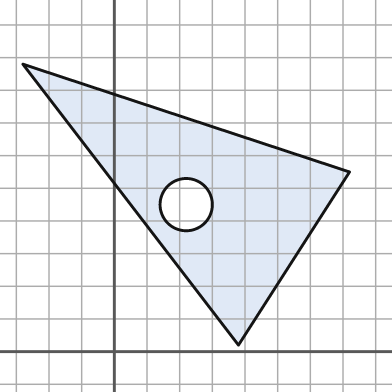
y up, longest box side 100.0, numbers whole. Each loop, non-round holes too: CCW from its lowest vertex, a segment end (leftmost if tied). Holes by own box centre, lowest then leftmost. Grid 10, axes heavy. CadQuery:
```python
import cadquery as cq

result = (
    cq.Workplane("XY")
    .moveTo(38.0, 2.0)
    .lineTo(72.0, 55.0)
    .lineTo(-28.0, 88.0)
    .close()
    .moveTo(22.0, 45.0)
    .circle(8.0)
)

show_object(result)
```